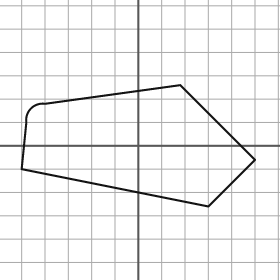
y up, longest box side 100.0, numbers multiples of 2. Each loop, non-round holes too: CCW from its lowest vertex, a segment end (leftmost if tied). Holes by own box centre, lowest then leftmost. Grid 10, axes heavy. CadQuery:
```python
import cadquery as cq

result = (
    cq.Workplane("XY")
    .moveTo(30.0, -26.0)
    .lineTo(50.0, -6.0)
    .lineTo(18.0, 26.0)
    .lineTo(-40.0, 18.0)
    .threePointArc((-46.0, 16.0), (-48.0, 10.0))
    .lineTo(-50.0, -10.0)
    .close()
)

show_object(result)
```